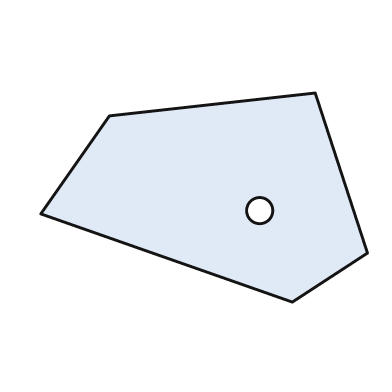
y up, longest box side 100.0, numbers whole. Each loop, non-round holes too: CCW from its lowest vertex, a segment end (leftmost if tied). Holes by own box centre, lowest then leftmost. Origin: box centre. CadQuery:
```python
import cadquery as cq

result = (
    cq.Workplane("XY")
    .moveTo(27.0, -32.0)
    .lineTo(50.0, -17.0)
    .lineTo(34.0, 32.0)
    .lineTo(-29.0, 25.0)
    .lineTo(-50.0, -5.0)
    .close()
    .moveTo(17.0, -4.0)
    .circle(4.0)
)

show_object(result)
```